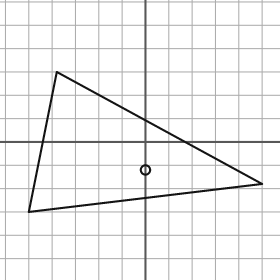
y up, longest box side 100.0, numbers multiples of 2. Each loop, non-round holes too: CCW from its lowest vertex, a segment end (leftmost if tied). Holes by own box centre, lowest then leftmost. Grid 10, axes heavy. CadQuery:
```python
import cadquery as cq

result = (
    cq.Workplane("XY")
    .moveTo(-50.0, -30.0)
    .lineTo(50.0, -18.0)
    .lineTo(-38.0, 30.0)
    .close()
    .moveTo(0.0, -12.0)
    .circle(2.0)
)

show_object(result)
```